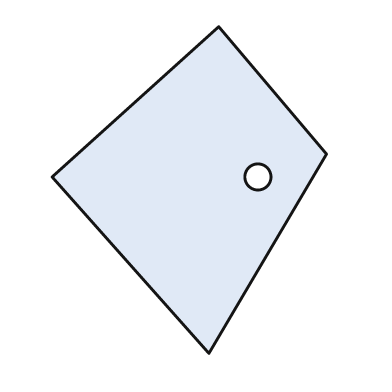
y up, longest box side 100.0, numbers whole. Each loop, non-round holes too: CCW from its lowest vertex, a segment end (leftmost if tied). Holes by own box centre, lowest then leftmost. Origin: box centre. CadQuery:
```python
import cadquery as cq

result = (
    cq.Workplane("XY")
    .moveTo(6.0, -50.0)
    .lineTo(42.0, 11.0)
    .lineTo(9.0, 50.0)
    .lineTo(-42.0, 4.0)
    .close()
    .moveTo(21.0, 4.0)
    .circle(4.0)
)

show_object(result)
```